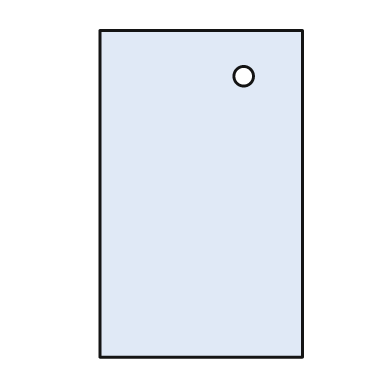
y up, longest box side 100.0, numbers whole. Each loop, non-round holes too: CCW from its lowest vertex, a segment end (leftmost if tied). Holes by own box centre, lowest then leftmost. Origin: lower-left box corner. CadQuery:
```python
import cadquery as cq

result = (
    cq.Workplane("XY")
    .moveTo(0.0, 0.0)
    .lineTo(62.0, 0.0)
    .lineTo(62.0, 100.0)
    .lineTo(0.0, 100.0)
    .close()
    .moveTo(44.0, 86.0)
    .circle(3.0)
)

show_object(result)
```